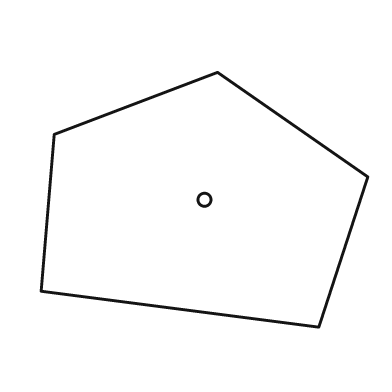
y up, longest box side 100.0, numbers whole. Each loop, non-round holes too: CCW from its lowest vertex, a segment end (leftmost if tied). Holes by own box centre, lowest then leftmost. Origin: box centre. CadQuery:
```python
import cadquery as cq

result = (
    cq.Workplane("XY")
    .moveTo(35.0, -39.0)
    .lineTo(50.0, 7.0)
    .lineTo(4.0, 39.0)
    .lineTo(-46.0, 20.0)
    .lineTo(-50.0, -28.0)
    .close()
    .moveTo(0.0, 0.0)
    .circle(2.0)
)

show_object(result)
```